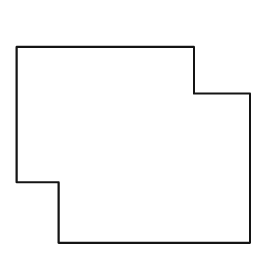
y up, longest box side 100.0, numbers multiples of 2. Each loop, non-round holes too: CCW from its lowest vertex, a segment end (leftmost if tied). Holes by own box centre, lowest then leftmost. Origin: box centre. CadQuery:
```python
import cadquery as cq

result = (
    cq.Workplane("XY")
    .moveTo(-32.0, -42.0)
    .lineTo(50.0, -42.0)
    .lineTo(50.0, 22.0)
    .lineTo(26.0, 22.0)
    .lineTo(26.0, 42.0)
    .lineTo(-50.0, 42.0)
    .lineTo(-50.0, -16.0)
    .lineTo(-32.0, -16.0)
    .close()
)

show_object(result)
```